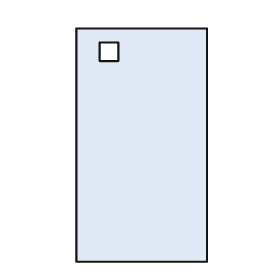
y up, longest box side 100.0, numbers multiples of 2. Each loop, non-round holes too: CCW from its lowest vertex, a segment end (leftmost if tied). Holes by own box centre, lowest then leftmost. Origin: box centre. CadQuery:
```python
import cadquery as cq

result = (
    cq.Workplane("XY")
    .moveTo(-28.0, -50.0)
    .lineTo(28.0, -50.0)
    .lineTo(28.0, 50.0)
    .lineTo(-28.0, 50.0)
    .close()
    .moveTo(-18.0, 36.0)
    .lineTo(-10.0, 36.0)
    .lineTo(-10.0, 44.0)
    .lineTo(-18.0, 44.0)
    .close()
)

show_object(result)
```